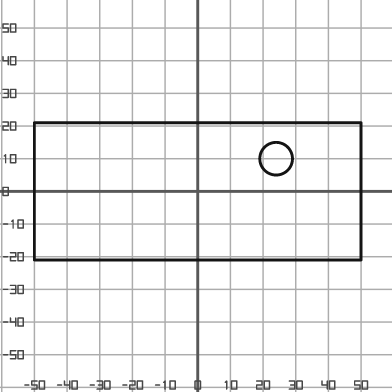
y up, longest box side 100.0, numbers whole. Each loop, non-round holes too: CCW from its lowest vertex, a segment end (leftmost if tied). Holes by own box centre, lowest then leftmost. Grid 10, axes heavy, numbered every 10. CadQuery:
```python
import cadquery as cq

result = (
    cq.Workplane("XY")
    .moveTo(-50.0, -21.0)
    .lineTo(50.0, -21.0)
    .lineTo(50.0, 21.0)
    .lineTo(-50.0, 21.0)
    .close()
    .moveTo(24.0, 10.0)
    .circle(5.0)
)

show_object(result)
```